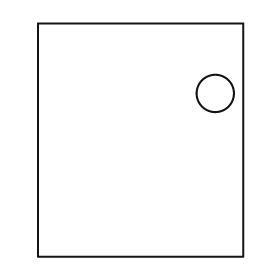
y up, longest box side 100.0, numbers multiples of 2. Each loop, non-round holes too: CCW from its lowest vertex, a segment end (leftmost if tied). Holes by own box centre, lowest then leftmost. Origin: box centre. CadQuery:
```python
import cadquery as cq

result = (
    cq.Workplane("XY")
    .moveTo(-44.0, -50.0)
    .lineTo(44.0, -50.0)
    .lineTo(44.0, 50.0)
    .lineTo(-44.0, 50.0)
    .close()
    .moveTo(32.0, 20.0)
    .circle(8.0)
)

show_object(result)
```